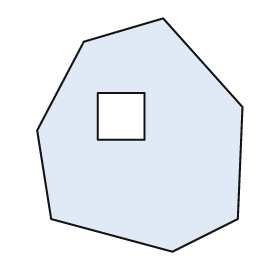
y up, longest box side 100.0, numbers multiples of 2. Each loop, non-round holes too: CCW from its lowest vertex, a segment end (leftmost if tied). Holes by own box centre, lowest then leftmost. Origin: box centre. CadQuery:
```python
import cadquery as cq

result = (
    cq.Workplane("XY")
    .moveTo(14.0, -50.0)
    .lineTo(42.0, -36.0)
    .lineTo(44.0, 12.0)
    .lineTo(10.0, 50.0)
    .lineTo(-24.0, 40.0)
    .lineTo(-44.0, 2.0)
    .lineTo(-38.0, -36.0)
    .close()
    .moveTo(-18.0, -2.0)
    .lineTo(2.0, -2.0)
    .lineTo(2.0, 18.0)
    .lineTo(-18.0, 18.0)
    .close()
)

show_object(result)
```